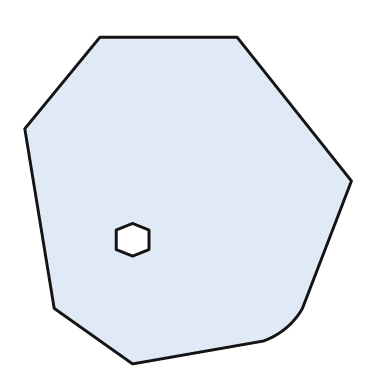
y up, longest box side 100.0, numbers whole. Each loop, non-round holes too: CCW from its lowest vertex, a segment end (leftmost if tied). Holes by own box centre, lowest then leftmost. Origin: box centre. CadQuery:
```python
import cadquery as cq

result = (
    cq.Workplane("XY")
    .moveTo(-17.0, -50.0)
    .lineTo(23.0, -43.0)
    .threePointArc((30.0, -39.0), (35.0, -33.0))
    .lineTo(50.0, 6.0)
    .lineTo(15.0, 50.0)
    .lineTo(-27.0, 50.0)
    .lineTo(-50.0, 22.0)
    .lineTo(-41.0, -33.0)
    .close()
    .moveTo(-17.0, -17.0)
    .lineTo(-12.0, -15.0)
    .lineTo(-12.0, -9.0)
    .lineTo(-17.0, -7.0)
    .lineTo(-22.0, -9.0)
    .lineTo(-22.0, -15.0)
    .close()
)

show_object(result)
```